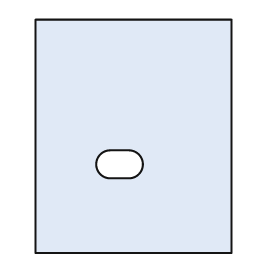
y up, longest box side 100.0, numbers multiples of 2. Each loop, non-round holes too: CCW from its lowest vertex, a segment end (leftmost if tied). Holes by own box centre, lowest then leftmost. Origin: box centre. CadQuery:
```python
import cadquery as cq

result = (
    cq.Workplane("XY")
    .moveTo(-42.0, -50.0)
    .lineTo(42.0, -50.0)
    .lineTo(42.0, 50.0)
    .lineTo(-42.0, 50.0)
    .close()
    .moveTo(-10.0, -18.0)
    .lineTo(-2.0, -18.0)
    .threePointArc((4.0, -12.0), (-2.0, -6.0))
    .lineTo(-10.0, -6.0)
    .threePointArc((-16.0, -12.0), (-10.0, -18.0))
    .close()
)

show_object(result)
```